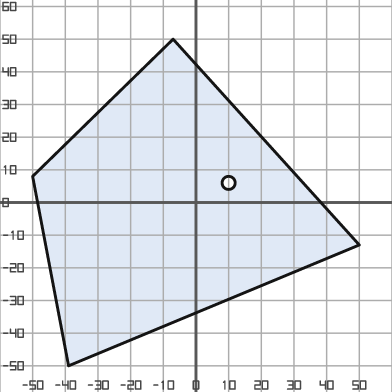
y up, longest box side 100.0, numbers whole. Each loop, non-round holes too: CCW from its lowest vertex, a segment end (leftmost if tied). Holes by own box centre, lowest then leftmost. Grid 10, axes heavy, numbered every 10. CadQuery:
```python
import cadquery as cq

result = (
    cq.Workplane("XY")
    .moveTo(-39.0, -50.0)
    .lineTo(50.0, -13.0)
    .lineTo(-7.0, 50.0)
    .lineTo(-50.0, 8.0)
    .close()
    .moveTo(10.0, 6.0)
    .circle(2.0)
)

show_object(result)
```